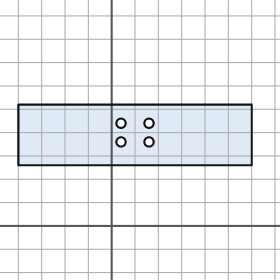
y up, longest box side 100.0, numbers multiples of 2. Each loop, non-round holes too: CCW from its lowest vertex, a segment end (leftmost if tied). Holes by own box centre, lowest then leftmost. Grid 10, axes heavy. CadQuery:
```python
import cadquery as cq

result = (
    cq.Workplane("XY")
    .moveTo(-40.0, 26.0)
    .lineTo(60.0, 26.0)
    .lineTo(60.0, 52.0)
    .lineTo(-40.0, 52.0)
    .close()
    .moveTo(4.0, 36.0)
    .circle(2.0)
    .moveTo(16.0, 36.0)
    .circle(2.0)
    .moveTo(4.0, 44.0)
    .circle(2.0)
    .moveTo(16.0, 44.0)
    .circle(2.0)
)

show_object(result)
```